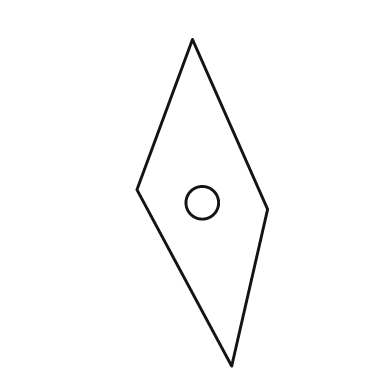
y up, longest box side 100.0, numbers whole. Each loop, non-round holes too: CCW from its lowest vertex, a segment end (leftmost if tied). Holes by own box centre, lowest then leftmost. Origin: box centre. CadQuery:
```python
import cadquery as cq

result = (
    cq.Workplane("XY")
    .moveTo(9.0, -50.0)
    .lineTo(20.0, -2.0)
    .lineTo(-3.0, 50.0)
    .lineTo(-20.0, 4.0)
    .close()
    .moveTo(0.0, 0.0)
    .circle(5.0)
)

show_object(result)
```